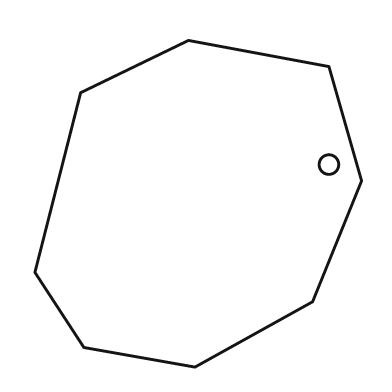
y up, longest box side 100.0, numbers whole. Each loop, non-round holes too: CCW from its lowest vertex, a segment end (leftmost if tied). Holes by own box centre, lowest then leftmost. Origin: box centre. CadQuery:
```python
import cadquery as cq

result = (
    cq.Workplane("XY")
    .moveTo(-1.0, -50.0)
    .lineTo(35.0, -30.0)
    .lineTo(50.0, 7.0)
    .lineTo(40.0, 42.0)
    .lineTo(-3.0, 50.0)
    .lineTo(-36.0, 34.0)
    .lineTo(-50.0, -21.0)
    .lineTo(-35.0, -44.0)
    .close()
    .moveTo(40.0, 12.0)
    .circle(3.0)
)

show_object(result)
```